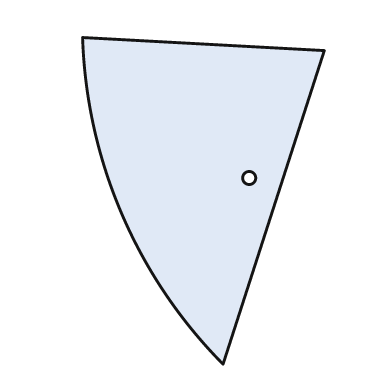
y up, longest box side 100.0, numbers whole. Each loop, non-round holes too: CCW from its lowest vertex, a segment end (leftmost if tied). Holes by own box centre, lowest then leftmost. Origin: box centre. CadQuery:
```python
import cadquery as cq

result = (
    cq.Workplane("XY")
    .moveTo(6.0, -50.0)
    .lineTo(37.0, 46.0)
    .lineTo(-37.0, 50.0)
    .threePointArc((-25.0, -4.0), (6.0, -50.0))
    .close()
    .moveTo(14.0, 7.0)
    .circle(2.0)
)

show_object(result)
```